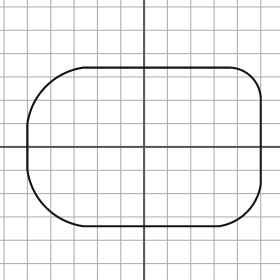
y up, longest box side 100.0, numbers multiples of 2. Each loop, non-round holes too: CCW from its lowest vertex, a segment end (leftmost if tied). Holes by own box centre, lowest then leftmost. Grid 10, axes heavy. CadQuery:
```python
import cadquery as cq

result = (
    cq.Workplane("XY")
    .moveTo(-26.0, -34.0)
    .lineTo(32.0, -34.0)
    .threePointArc((44.0, -28.0), (50.0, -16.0))
    .lineTo(50.0, 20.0)
    .threePointArc((46.0, 30.0), (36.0, 34.0))
    .lineTo(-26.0, 34.0)
    .threePointArc((-42.0, 26.0), (-50.0, 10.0))
    .lineTo(-50.0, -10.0)
    .threePointArc((-42.0, -26.0), (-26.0, -34.0))
    .close()
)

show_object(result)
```